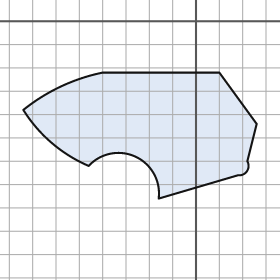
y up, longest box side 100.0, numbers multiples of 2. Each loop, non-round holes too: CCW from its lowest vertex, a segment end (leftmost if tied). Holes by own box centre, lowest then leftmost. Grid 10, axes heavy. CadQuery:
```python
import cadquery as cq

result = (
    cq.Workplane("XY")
    .moveTo(-16.0, -76.0)
    .lineTo(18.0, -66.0)
    .threePointArc((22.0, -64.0), (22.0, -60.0))
    .lineTo(26.0, -44.0)
    .lineTo(10.0, -22.0)
    .lineTo(-40.0, -22.0)
    .threePointArc((-58.0, -28.0), (-74.0, -38.0))
    .threePointArc((-62.0, -52.0), (-46.0, -62.0))
    .threePointArc((-26.0, -58.0), (-16.0, -76.0))
    .close()
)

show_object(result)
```